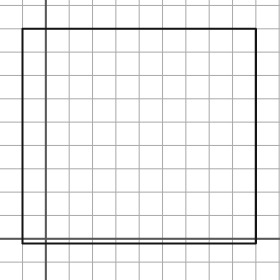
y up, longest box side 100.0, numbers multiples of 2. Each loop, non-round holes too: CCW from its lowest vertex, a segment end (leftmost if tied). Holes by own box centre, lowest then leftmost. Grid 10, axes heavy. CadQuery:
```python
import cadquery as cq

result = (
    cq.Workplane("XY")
    .moveTo(-10.0, -2.0)
    .lineTo(90.0, -2.0)
    .lineTo(90.0, 90.0)
    .lineTo(-10.0, 90.0)
    .close()
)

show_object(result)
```